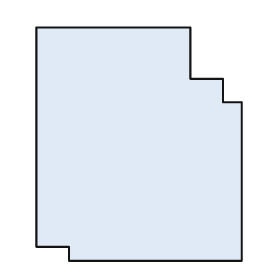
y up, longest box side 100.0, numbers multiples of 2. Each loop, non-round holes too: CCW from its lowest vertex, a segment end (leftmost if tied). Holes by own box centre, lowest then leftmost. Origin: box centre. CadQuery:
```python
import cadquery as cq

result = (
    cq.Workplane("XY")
    .moveTo(-30.0, -50.0)
    .lineTo(44.0, -50.0)
    .lineTo(44.0, 18.0)
    .lineTo(36.0, 18.0)
    .lineTo(36.0, 28.0)
    .lineTo(22.0, 28.0)
    .lineTo(22.0, 50.0)
    .lineTo(-44.0, 50.0)
    .lineTo(-44.0, -44.0)
    .lineTo(-30.0, -44.0)
    .close()
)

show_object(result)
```